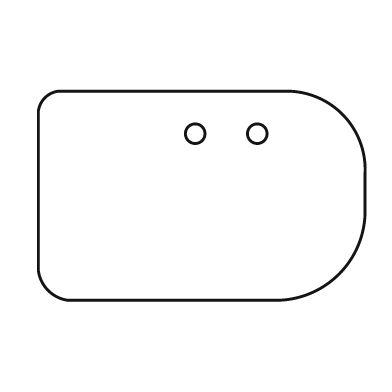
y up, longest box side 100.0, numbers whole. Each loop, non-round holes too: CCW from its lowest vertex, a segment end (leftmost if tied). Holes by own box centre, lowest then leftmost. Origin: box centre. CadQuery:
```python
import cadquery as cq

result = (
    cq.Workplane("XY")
    .moveTo(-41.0, -32.0)
    .lineTo(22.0, -32.0)
    .threePointArc((42.0, -24.0), (50.0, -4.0))
    .lineTo(50.0, 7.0)
    .threePointArc((43.0, 25.0), (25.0, 32.0))
    .lineTo(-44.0, 32.0)
    .threePointArc((-48.0, 30.0), (-50.0, 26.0))
    .lineTo(-50.0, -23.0)
    .threePointArc((-47.0, -29.0), (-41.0, -32.0))
    .close()
    .moveTo(-2.0, 19.0)
    .circle(3.0)
    .moveTo(17.0, 19.0)
    .circle(3.0)
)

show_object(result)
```